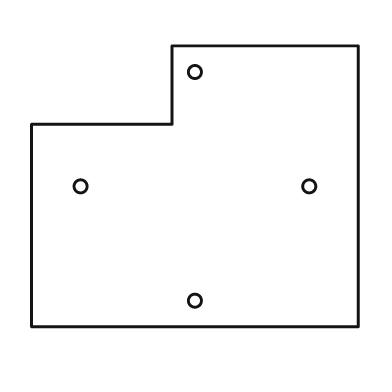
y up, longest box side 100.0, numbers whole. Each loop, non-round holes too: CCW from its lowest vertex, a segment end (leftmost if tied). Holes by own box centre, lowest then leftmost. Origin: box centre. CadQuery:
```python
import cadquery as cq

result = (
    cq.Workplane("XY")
    .moveTo(-50.0, -43.0)
    .lineTo(50.0, -43.0)
    .lineTo(50.0, 43.0)
    .lineTo(-7.0, 43.0)
    .lineTo(-7.0, 19.0)
    .lineTo(-50.0, 19.0)
    .close()
    .moveTo(0.0, -35.0)
    .circle(2.0)
    .moveTo(-35.0, 0.0)
    .circle(2.0)
    .moveTo(35.0, 0.0)
    .circle(2.0)
    .moveTo(0.0, 35.0)
    .circle(2.0)
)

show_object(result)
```